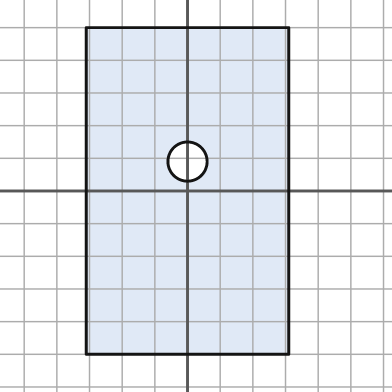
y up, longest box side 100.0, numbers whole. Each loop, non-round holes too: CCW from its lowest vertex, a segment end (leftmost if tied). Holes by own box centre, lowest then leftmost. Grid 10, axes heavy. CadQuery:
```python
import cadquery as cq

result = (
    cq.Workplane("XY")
    .moveTo(-31.0, -50.0)
    .lineTo(31.0, -50.0)
    .lineTo(31.0, 50.0)
    .lineTo(-31.0, 50.0)
    .close()
    .moveTo(0.0, 9.0)
    .circle(6.0)
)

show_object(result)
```